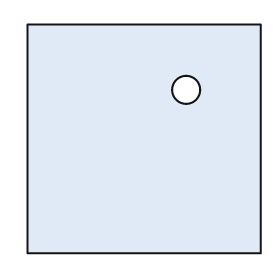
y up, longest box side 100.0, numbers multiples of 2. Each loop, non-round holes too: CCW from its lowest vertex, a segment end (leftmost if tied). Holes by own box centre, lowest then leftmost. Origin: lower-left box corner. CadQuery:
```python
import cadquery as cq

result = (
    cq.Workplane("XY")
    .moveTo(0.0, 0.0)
    .lineTo(100.0, 0.0)
    .lineTo(100.0, 98.0)
    .lineTo(0.0, 98.0)
    .close()
    .moveTo(68.0, 70.0)
    .circle(6.0)
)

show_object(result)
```